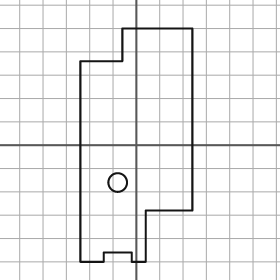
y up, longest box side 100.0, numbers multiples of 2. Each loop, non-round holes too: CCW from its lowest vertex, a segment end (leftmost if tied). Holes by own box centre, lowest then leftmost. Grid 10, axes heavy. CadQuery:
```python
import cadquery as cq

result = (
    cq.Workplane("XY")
    .moveTo(-24.0, -50.0)
    .lineTo(-14.0, -50.0)
    .lineTo(-14.0, -46.0)
    .lineTo(-2.0, -46.0)
    .lineTo(-2.0, -50.0)
    .lineTo(4.0, -50.0)
    .lineTo(4.0, -28.0)
    .lineTo(24.0, -28.0)
    .lineTo(24.0, 50.0)
    .lineTo(-6.0, 50.0)
    .lineTo(-6.0, 36.0)
    .lineTo(-24.0, 36.0)
    .close()
    .moveTo(-8.0, -16.0)
    .circle(4.0)
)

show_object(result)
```